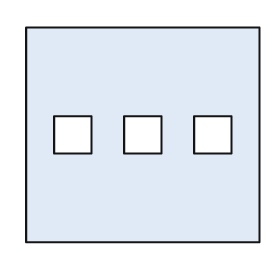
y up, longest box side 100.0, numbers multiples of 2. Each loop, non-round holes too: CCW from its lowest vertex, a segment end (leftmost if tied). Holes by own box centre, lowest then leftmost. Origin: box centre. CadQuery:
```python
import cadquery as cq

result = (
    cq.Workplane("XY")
    .moveTo(-50.0, -46.0)
    .lineTo(50.0, -46.0)
    .lineTo(50.0, 46.0)
    .lineTo(-50.0, 46.0)
    .close()
    .moveTo(-38.0, -8.0)
    .lineTo(-22.0, -8.0)
    .lineTo(-22.0, 8.0)
    .lineTo(-38.0, 8.0)
    .close()
    .moveTo(-8.0, -8.0)
    .lineTo(8.0, -8.0)
    .lineTo(8.0, 8.0)
    .lineTo(-8.0, 8.0)
    .close()
    .moveTo(22.0, -8.0)
    .lineTo(38.0, -8.0)
    .lineTo(38.0, 8.0)
    .lineTo(22.0, 8.0)
    .close()
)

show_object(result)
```